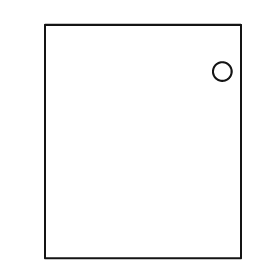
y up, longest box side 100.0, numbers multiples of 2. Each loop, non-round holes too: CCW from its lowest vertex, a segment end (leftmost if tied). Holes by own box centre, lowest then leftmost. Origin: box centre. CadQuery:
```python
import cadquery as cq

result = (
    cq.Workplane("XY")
    .moveTo(-42.0, -50.0)
    .lineTo(42.0, -50.0)
    .lineTo(42.0, 50.0)
    .lineTo(-42.0, 50.0)
    .close()
    .moveTo(34.0, 30.0)
    .circle(4.0)
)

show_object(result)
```